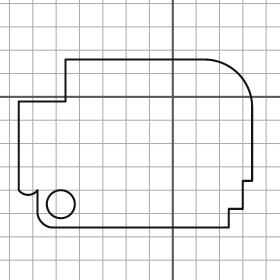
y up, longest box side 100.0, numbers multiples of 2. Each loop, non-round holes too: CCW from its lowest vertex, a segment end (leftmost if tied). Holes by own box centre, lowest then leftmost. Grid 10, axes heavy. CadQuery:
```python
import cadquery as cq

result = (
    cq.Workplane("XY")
    .moveTo(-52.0, -56.0)
    .lineTo(24.0, -56.0)
    .lineTo(24.0, -48.0)
    .lineTo(30.0, -48.0)
    .lineTo(30.0, -36.0)
    .lineTo(34.0, -36.0)
    .lineTo(34.0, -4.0)
    .threePointArc((28.0, 10.0), (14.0, 16.0))
    .lineTo(-46.0, 16.0)
    .lineTo(-46.0, -2.0)
    .lineTo(-66.0, -2.0)
    .lineTo(-66.0, -40.0)
    .threePointArc((-62.0, -42.0), (-58.0, -40.0))
    .lineTo(-58.0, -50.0)
    .threePointArc((-56.0, -54.0), (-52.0, -56.0))
    .close()
    .moveTo(-48.0, -46.0)
    .circle(6.0)
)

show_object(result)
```